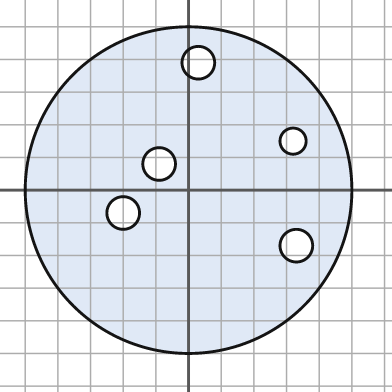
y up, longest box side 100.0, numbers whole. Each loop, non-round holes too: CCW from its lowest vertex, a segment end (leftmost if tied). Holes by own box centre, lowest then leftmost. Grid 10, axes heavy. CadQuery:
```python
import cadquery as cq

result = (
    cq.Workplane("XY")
    .moveTo(0.0, 0.0)
    .circle(50.0)
    .moveTo(33.0, -17.0)
    .circle(5.0)
    .moveTo(-20.0, -7.0)
    .circle(5.0)
    .moveTo(-9.0, 8.0)
    .circle(5.0)
    .moveTo(32.0, 15.0)
    .circle(4.0)
    .moveTo(3.0, 39.0)
    .circle(5.0)
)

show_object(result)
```